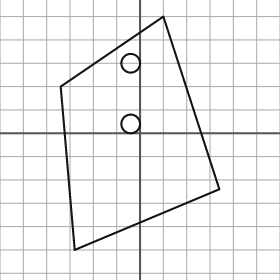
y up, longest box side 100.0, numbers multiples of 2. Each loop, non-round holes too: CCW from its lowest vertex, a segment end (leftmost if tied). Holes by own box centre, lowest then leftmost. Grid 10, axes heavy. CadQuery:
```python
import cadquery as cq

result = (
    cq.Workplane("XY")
    .moveTo(-28.0, -50.0)
    .lineTo(34.0, -24.0)
    .lineTo(10.0, 50.0)
    .lineTo(-34.0, 20.0)
    .close()
    .moveTo(-4.0, 4.0)
    .circle(4.0)
    .moveTo(-4.0, 30.0)
    .circle(4.0)
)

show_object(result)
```